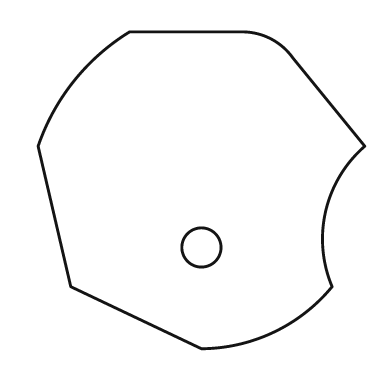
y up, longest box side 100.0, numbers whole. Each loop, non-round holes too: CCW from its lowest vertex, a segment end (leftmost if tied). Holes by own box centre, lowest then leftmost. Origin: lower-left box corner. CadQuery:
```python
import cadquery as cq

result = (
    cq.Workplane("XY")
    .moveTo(50.0, 0.0)
    .threePointArc((72.0, 5.0), (90.0, 19.0))
    .threePointArc((88.0, 42.0), (100.0, 62.0))
    .lineTo(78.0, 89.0)
    .threePointArc((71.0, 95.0), (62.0, 97.0))
    .lineTo(28.0, 97.0)
    .threePointArc((11.0, 82.0), (0.0, 62.0))
    .lineTo(10.0, 19.0)
    .close()
    .moveTo(50.0, 31.0)
    .circle(6.0)
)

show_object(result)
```